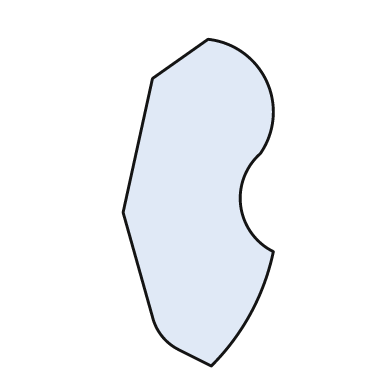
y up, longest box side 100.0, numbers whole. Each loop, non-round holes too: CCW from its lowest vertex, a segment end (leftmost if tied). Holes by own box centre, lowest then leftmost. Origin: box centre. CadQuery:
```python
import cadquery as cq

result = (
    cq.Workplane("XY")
    .moveTo(4.0, -50.0)
    .threePointArc((16.0, -34.0), (23.0, -15.0))
    .threePointArc((13.0, -1.0), (19.0, 15.0))
    .threePointArc((21.0, 37.0), (3.0, 50.0))
    .lineTo(-14.0, 38.0)
    .lineTo(-23.0, -3.0)
    .lineTo(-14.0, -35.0)
    .threePointArc((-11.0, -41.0), (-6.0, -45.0))
    .close()
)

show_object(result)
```